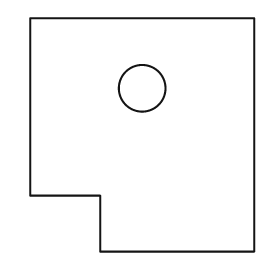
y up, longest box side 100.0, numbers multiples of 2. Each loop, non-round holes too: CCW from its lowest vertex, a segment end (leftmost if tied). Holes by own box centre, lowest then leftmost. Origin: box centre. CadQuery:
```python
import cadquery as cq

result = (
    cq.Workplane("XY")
    .moveTo(-18.0, -50.0)
    .lineTo(48.0, -50.0)
    .lineTo(48.0, 50.0)
    .lineTo(-48.0, 50.0)
    .lineTo(-48.0, -26.0)
    .lineTo(-18.0, -26.0)
    .close()
    .moveTo(0.0, 20.0)
    .circle(10.0)
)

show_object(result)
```